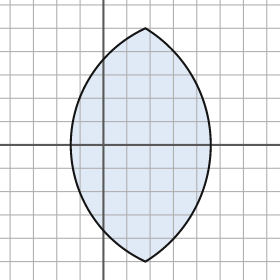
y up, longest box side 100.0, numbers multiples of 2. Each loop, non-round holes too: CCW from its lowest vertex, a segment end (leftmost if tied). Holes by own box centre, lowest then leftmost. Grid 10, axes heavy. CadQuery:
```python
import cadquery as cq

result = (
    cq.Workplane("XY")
    .moveTo(18.0, -50.0)
    .threePointArc((46.0, 0.0), (18.0, 50.0))
    .threePointArc((-14.0, 0.0), (18.0, -50.0))
    .close()
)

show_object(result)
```